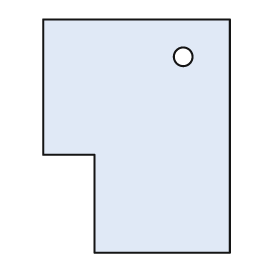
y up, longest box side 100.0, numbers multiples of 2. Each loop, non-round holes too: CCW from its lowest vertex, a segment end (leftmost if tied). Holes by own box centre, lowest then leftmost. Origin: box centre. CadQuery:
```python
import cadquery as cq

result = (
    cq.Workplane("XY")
    .moveTo(-18.0, -50.0)
    .lineTo(40.0, -50.0)
    .lineTo(40.0, 50.0)
    .lineTo(-40.0, 50.0)
    .lineTo(-40.0, -8.0)
    .lineTo(-18.0, -8.0)
    .close()
    .moveTo(20.0, 34.0)
    .circle(4.0)
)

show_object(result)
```